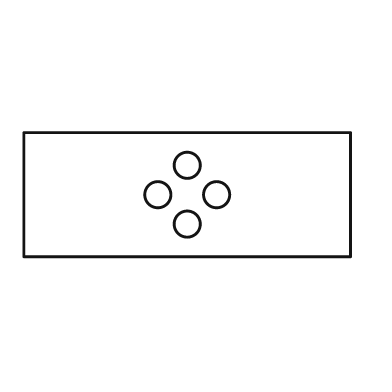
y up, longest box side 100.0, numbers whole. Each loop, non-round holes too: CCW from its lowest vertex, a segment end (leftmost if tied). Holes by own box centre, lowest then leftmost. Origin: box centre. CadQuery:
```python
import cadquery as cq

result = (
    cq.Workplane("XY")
    .moveTo(-50.0, -19.0)
    .lineTo(50.0, -19.0)
    .lineTo(50.0, 19.0)
    .lineTo(-50.0, 19.0)
    .close()
    .moveTo(0.0, -9.0)
    .circle(4.0)
    .moveTo(-9.0, 0.0)
    .circle(4.0)
    .moveTo(9.0, 0.0)
    .circle(4.0)
    .moveTo(0.0, 9.0)
    .circle(4.0)
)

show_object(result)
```